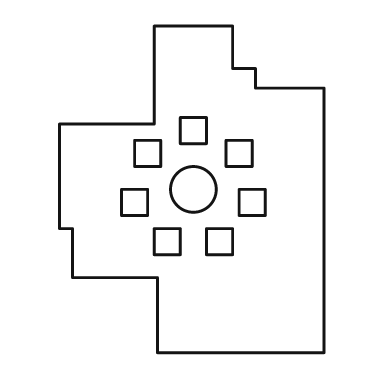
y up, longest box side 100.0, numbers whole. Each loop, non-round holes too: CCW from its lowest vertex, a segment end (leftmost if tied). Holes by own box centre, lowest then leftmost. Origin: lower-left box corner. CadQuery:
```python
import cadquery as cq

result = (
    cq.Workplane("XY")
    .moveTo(30.0, 0.0)
    .lineTo(81.0, 0.0)
    .lineTo(81.0, 81.0)
    .lineTo(60.0, 81.0)
    .lineTo(60.0, 87.0)
    .lineTo(53.0, 87.0)
    .lineTo(53.0, 100.0)
    .lineTo(29.0, 100.0)
    .lineTo(29.0, 70.0)
    .lineTo(0.0, 70.0)
    .lineTo(0.0, 38.0)
    .lineTo(4.0, 38.0)
    .lineTo(4.0, 23.0)
    .lineTo(30.0, 23.0)
    .close()
    .moveTo(29.0, 30.0)
    .lineTo(37.0, 30.0)
    .lineTo(37.0, 38.0)
    .lineTo(29.0, 38.0)
    .close()
    .moveTo(45.0, 30.0)
    .lineTo(53.0, 30.0)
    .lineTo(53.0, 38.0)
    .lineTo(45.0, 38.0)
    .close()
    .moveTo(19.0, 42.0)
    .lineTo(27.0, 42.0)
    .lineTo(27.0, 50.0)
    .lineTo(19.0, 50.0)
    .close()
    .moveTo(55.0, 42.0)
    .lineTo(63.0, 42.0)
    .lineTo(63.0, 50.0)
    .lineTo(55.0, 50.0)
    .close()
    .moveTo(41.0, 50.0)
    .circle(7.0)
    .moveTo(23.0, 57.0)
    .lineTo(31.0, 57.0)
    .lineTo(31.0, 65.0)
    .lineTo(23.0, 65.0)
    .close()
    .moveTo(51.0, 57.0)
    .lineTo(59.0, 57.0)
    .lineTo(59.0, 65.0)
    .lineTo(51.0, 65.0)
    .close()
    .moveTo(37.0, 64.0)
    .lineTo(45.0, 64.0)
    .lineTo(45.0, 72.0)
    .lineTo(37.0, 72.0)
    .close()
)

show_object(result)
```